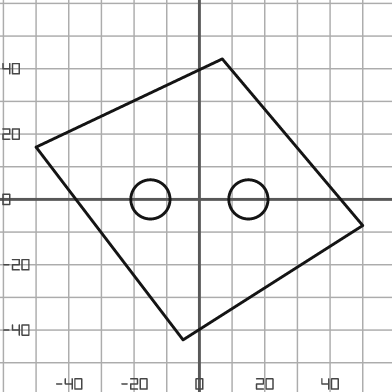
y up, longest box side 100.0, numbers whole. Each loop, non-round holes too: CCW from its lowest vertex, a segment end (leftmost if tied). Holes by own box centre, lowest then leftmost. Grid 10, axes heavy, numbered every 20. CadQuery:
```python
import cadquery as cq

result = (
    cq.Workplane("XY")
    .moveTo(-5.0, -43.0)
    .lineTo(50.0, -8.0)
    .lineTo(7.0, 43.0)
    .lineTo(-50.0, 16.0)
    .close()
    .moveTo(-15.0, 0.0)
    .circle(6.0)
    .moveTo(15.0, 0.0)
    .circle(6.0)
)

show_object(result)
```